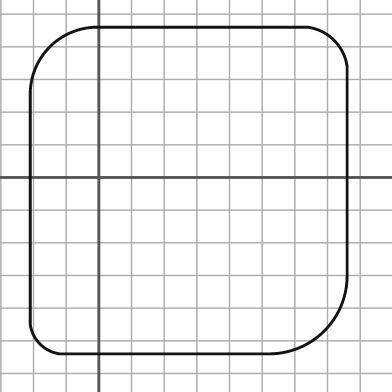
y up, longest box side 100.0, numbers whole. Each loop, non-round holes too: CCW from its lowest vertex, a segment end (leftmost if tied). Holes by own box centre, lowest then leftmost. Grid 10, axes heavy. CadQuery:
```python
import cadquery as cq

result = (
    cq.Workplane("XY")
    .moveTo(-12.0, -54.0)
    .lineTo(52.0, -54.0)
    .threePointArc((69.0, -47.0), (76.0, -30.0))
    .lineTo(76.0, 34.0)
    .threePointArc((72.0, 42.0), (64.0, 46.0))
    .lineTo(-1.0, 46.0)
    .threePointArc((-15.0, 40.0), (-21.0, 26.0))
    .lineTo(-21.0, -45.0)
    .threePointArc((-18.0, -51.0), (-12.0, -54.0))
    .close()
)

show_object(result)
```